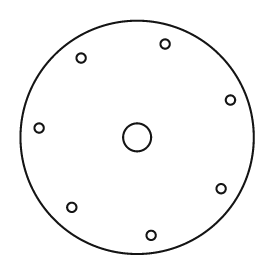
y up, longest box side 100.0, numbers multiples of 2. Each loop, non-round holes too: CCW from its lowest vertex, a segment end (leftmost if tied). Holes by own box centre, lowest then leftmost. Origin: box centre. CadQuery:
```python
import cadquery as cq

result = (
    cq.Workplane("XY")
    .moveTo(0.0, 0.0)
    .circle(50.0)
    .moveTo(6.0, -42.0)
    .circle(2.0)
    .moveTo(-28.0, -30.0)
    .circle(2.0)
    .moveTo(36.0, -22.0)
    .circle(2.0)
    .moveTo(0.0, 0.0)
    .circle(6.0)
    .moveTo(-42.0, 4.0)
    .circle(2.0)
    .moveTo(40.0, 16.0)
    .circle(2.0)
    .moveTo(-24.0, 34.0)
    .circle(2.0)
    .moveTo(12.0, 40.0)
    .circle(2.0)
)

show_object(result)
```